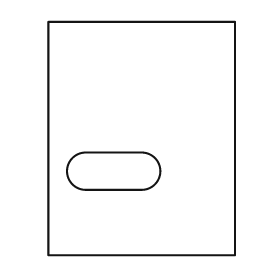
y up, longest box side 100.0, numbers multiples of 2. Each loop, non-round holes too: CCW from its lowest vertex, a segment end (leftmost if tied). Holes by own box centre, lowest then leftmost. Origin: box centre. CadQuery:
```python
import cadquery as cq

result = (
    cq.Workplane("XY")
    .moveTo(-40.0, -50.0)
    .lineTo(40.0, -50.0)
    .lineTo(40.0, 50.0)
    .lineTo(-40.0, 50.0)
    .close()
    .moveTo(-24.0, -22.0)
    .lineTo(0.0, -22.0)
    .threePointArc((8.0, -14.0), (0.0, -6.0))
    .lineTo(-24.0, -6.0)
    .threePointArc((-32.0, -14.0), (-24.0, -22.0))
    .close()
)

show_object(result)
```